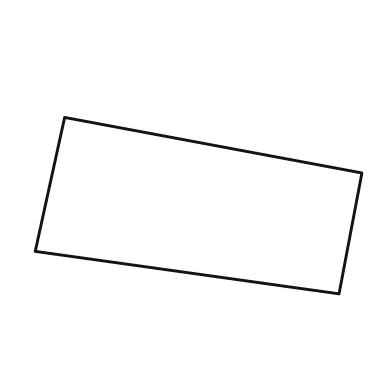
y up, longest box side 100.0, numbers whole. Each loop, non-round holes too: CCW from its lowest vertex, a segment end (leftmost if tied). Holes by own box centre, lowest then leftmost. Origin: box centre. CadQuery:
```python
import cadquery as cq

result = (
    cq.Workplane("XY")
    .moveTo(43.0, -27.0)
    .lineTo(50.0, 10.0)
    .lineTo(-41.0, 27.0)
    .lineTo(-50.0, -14.0)
    .close()
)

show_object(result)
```